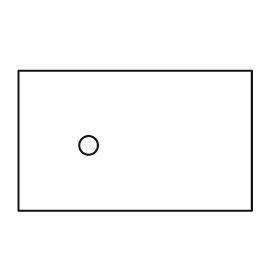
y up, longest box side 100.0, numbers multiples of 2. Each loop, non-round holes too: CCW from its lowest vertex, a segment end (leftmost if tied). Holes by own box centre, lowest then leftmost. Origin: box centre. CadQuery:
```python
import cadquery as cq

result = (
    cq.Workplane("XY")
    .moveTo(-50.0, -30.0)
    .lineTo(50.0, -30.0)
    .lineTo(50.0, 30.0)
    .lineTo(-50.0, 30.0)
    .close()
    .moveTo(-20.0, -2.0)
    .circle(4.0)
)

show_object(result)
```